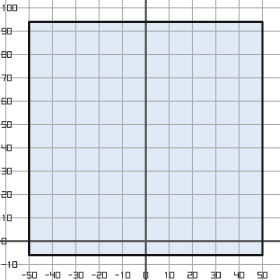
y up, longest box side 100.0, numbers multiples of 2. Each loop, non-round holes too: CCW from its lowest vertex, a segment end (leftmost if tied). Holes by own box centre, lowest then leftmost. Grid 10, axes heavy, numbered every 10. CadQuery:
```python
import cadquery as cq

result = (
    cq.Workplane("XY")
    .moveTo(-50.0, -6.0)
    .lineTo(50.0, -6.0)
    .lineTo(50.0, 94.0)
    .lineTo(-50.0, 94.0)
    .close()
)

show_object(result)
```